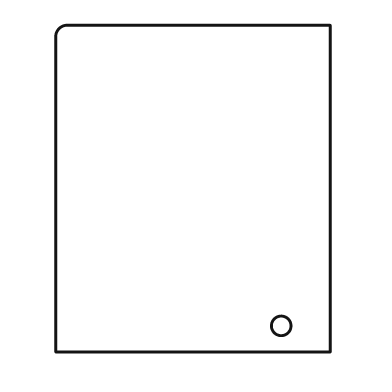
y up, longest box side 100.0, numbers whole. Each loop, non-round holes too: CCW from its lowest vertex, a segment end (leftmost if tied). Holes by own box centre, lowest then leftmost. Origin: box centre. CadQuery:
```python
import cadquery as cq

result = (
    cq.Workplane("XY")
    .moveTo(-42.0, -50.0)
    .lineTo(42.0, -50.0)
    .lineTo(42.0, 50.0)
    .lineTo(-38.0, 50.0)
    .threePointArc((-41.0, 49.0), (-42.0, 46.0))
    .close()
    .moveTo(27.0, -42.0)
    .circle(3.0)
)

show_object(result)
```